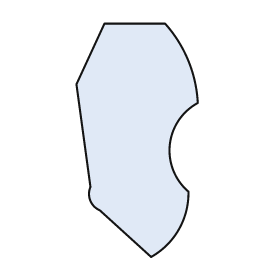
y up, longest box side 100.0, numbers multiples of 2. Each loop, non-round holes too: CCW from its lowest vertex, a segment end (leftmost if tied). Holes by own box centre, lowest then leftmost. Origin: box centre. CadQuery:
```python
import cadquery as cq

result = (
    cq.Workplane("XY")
    .moveTo(6.0, -50.0)
    .threePointArc((18.0, -38.0), (22.0, -22.0))
    .threePointArc((14.0, -2.0), (26.0, 16.0))
    .threePointArc((22.0, 34.0), (12.0, 50.0))
    .lineTo(-14.0, 50.0)
    .lineTo(-26.0, 24.0)
    .lineTo(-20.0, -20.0)
    .threePointArc((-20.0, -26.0), (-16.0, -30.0))
    .close()
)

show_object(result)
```